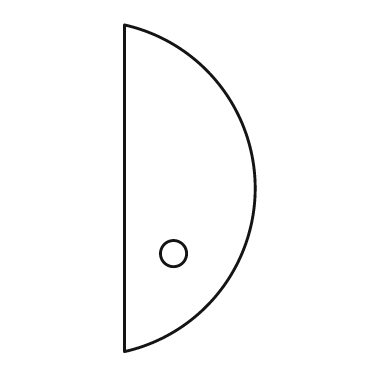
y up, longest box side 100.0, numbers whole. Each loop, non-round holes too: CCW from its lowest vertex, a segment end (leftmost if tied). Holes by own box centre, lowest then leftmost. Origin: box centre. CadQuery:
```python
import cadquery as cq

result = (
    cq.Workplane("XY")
    .moveTo(-20.0, -50.0)
    .threePointArc((20.0, 0.0), (-20.0, 50.0))
    .close()
    .moveTo(-5.0, -20.0)
    .circle(4.0)
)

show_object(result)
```